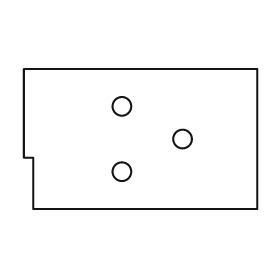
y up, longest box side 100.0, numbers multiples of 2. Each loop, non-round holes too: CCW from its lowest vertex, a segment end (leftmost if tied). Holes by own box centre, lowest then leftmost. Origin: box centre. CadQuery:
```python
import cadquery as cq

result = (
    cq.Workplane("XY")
    .moveTo(-46.0, -30.0)
    .lineTo(50.0, -30.0)
    .lineTo(50.0, 30.0)
    .lineTo(-50.0, 30.0)
    .lineTo(-50.0, -8.0)
    .lineTo(-46.0, -8.0)
    .close()
    .moveTo(-8.0, -14.0)
    .circle(4.0)
    .moveTo(18.0, 0.0)
    .circle(4.0)
    .moveTo(-8.0, 14.0)
    .circle(4.0)
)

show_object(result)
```